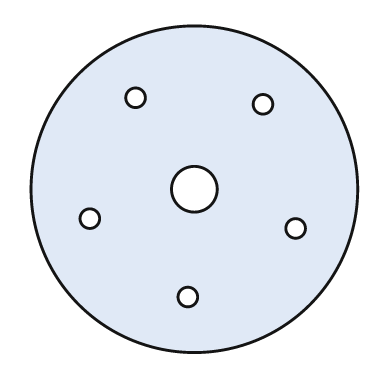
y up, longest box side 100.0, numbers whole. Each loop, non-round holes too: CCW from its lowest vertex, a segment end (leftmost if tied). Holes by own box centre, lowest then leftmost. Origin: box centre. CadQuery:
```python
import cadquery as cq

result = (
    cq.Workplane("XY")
    .moveTo(0.0, 0.0)
    .circle(50.0)
    .moveTo(-2.0, -33.0)
    .circle(3.0)
    .moveTo(31.0, -12.0)
    .circle(3.0)
    .moveTo(-32.0, -9.0)
    .circle(3.0)
    .moveTo(0.0, 0.0)
    .circle(7.0)
    .moveTo(21.0, 26.0)
    .circle(3.0)
    .moveTo(-18.0, 28.0)
    .circle(3.0)
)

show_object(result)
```